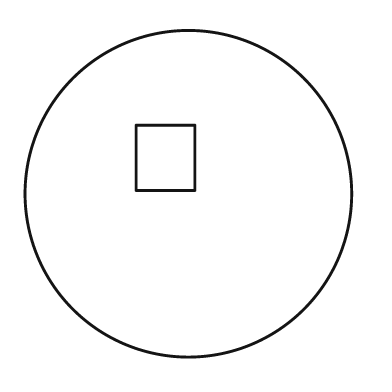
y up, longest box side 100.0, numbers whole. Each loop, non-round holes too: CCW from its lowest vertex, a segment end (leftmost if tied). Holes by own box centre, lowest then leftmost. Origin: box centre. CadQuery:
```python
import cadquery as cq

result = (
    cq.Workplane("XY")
    .moveTo(0.0, 0.0)
    .circle(50.0)
    .moveTo(-16.0, 1.0)
    .lineTo(2.0, 1.0)
    .lineTo(2.0, 21.0)
    .lineTo(-16.0, 21.0)
    .close()
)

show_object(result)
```